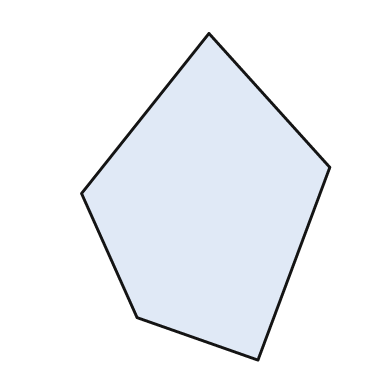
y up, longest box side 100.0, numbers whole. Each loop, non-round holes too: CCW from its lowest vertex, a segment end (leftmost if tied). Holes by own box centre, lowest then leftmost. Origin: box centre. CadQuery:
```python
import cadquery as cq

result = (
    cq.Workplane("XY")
    .moveTo(16.0, -50.0)
    .lineTo(38.0, 9.0)
    .lineTo(1.0, 50.0)
    .lineTo(-38.0, 1.0)
    .lineTo(-21.0, -37.0)
    .close()
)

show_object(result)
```